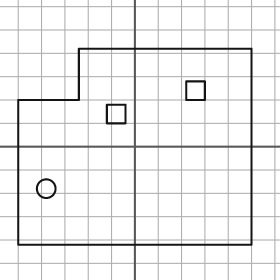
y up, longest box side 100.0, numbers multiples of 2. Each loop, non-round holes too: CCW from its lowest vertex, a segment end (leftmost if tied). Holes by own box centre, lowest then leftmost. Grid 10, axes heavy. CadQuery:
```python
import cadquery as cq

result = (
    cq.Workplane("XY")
    .moveTo(-50.0, -42.0)
    .lineTo(50.0, -42.0)
    .lineTo(50.0, 42.0)
    .lineTo(-24.0, 42.0)
    .lineTo(-24.0, 20.0)
    .lineTo(-50.0, 20.0)
    .close()
    .moveTo(-38.0, -18.0)
    .circle(4.0)
    .moveTo(-12.0, 10.0)
    .lineTo(-4.0, 10.0)
    .lineTo(-4.0, 18.0)
    .lineTo(-12.0, 18.0)
    .close()
    .moveTo(22.0, 20.0)
    .lineTo(30.0, 20.0)
    .lineTo(30.0, 28.0)
    .lineTo(22.0, 28.0)
    .close()
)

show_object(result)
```